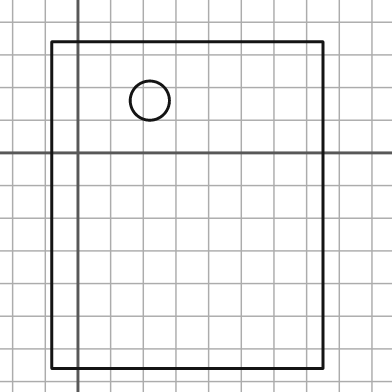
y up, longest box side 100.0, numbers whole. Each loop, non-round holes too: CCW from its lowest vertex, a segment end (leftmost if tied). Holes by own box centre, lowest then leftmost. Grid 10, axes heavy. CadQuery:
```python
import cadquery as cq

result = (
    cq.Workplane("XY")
    .moveTo(-8.0, -66.0)
    .lineTo(75.0, -66.0)
    .lineTo(75.0, 34.0)
    .lineTo(-8.0, 34.0)
    .close()
    .moveTo(22.0, 16.0)
    .circle(6.0)
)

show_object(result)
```